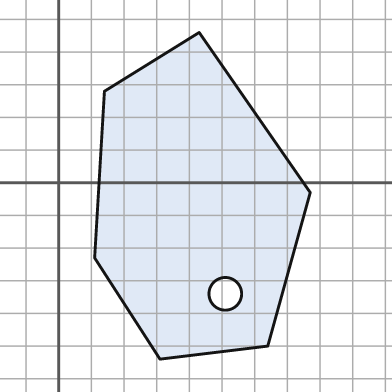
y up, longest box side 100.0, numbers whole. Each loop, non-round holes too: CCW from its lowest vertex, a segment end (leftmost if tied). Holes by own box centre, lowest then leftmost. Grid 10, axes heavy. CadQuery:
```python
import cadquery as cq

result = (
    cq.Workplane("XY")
    .moveTo(31.0, -54.0)
    .lineTo(64.0, -50.0)
    .lineTo(77.0, -3.0)
    .lineTo(43.0, 46.0)
    .lineTo(14.0, 28.0)
    .lineTo(11.0, -23.0)
    .close()
    .moveTo(51.0, -34.0)
    .circle(5.0)
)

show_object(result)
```